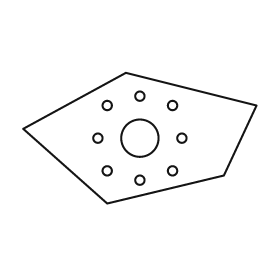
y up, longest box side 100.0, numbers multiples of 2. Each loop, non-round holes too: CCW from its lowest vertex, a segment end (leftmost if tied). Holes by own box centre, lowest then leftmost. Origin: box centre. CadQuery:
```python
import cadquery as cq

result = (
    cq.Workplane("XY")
    .moveTo(-14.0, -28.0)
    .lineTo(36.0, -16.0)
    .lineTo(50.0, 14.0)
    .lineTo(-6.0, 28.0)
    .lineTo(-50.0, 4.0)
    .close()
    .moveTo(0.0, -18.0)
    .circle(2.0)
    .moveTo(-14.0, -14.0)
    .circle(2.0)
    .moveTo(14.0, -14.0)
    .circle(2.0)
    .moveTo(-18.0, 0.0)
    .circle(2.0)
    .moveTo(0.0, 0.0)
    .circle(8.0)
    .moveTo(18.0, 0.0)
    .circle(2.0)
    .moveTo(-14.0, 14.0)
    .circle(2.0)
    .moveTo(14.0, 14.0)
    .circle(2.0)
    .moveTo(0.0, 18.0)
    .circle(2.0)
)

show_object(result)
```